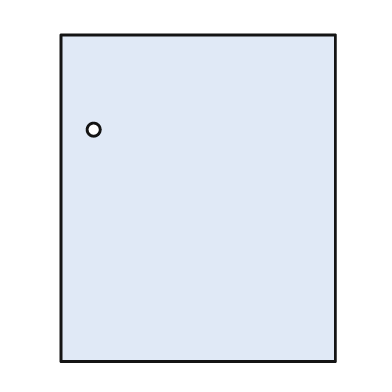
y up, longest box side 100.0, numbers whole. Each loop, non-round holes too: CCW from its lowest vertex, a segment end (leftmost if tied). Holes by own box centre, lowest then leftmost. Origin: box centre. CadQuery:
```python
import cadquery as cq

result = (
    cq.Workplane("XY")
    .moveTo(-42.0, -50.0)
    .lineTo(42.0, -50.0)
    .lineTo(42.0, 50.0)
    .lineTo(-42.0, 50.0)
    .close()
    .moveTo(-32.0, 21.0)
    .circle(2.0)
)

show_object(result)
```